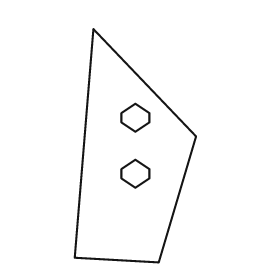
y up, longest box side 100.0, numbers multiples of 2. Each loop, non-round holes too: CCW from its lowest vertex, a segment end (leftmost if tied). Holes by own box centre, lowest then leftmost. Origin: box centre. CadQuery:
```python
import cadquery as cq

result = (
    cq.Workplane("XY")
    .moveTo(10.0, -50.0)
    .lineTo(26.0, 4.0)
    .lineTo(-18.0, 50.0)
    .lineTo(-26.0, -48.0)
    .close()
    .moveTo(0.0, -18.0)
    .lineTo(6.0, -14.0)
    .lineTo(6.0, -10.0)
    .lineTo(0.0, -6.0)
    .lineTo(-6.0, -10.0)
    .lineTo(-6.0, -14.0)
    .close()
    .moveTo(0.0, 6.0)
    .lineTo(6.0, 10.0)
    .lineTo(6.0, 14.0)
    .lineTo(0.0, 18.0)
    .lineTo(-6.0, 14.0)
    .lineTo(-6.0, 10.0)
    .close()
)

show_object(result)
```